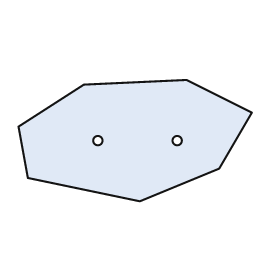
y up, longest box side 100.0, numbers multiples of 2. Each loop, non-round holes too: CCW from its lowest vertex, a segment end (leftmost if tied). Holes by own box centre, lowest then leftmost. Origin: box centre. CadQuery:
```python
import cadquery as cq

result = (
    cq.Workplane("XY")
    .moveTo(2.0, -26.0)
    .lineTo(36.0, -12.0)
    .lineTo(50.0, 12.0)
    .lineTo(22.0, 26.0)
    .lineTo(-22.0, 24.0)
    .lineTo(-50.0, 6.0)
    .lineTo(-46.0, -16.0)
    .close()
    .moveTo(-16.0, 0.0)
    .circle(2.0)
    .moveTo(18.0, 0.0)
    .circle(2.0)
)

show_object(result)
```